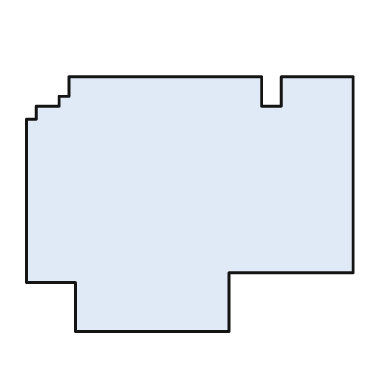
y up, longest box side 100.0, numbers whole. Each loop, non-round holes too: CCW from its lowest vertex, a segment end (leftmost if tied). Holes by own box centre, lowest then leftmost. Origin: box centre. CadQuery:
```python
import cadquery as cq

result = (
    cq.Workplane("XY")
    .moveTo(-35.0, -39.0)
    .lineTo(12.0, -39.0)
    .lineTo(12.0, -21.0)
    .lineTo(50.0, -21.0)
    .lineTo(50.0, 39.0)
    .lineTo(28.0, 39.0)
    .lineTo(28.0, 30.0)
    .lineTo(22.0, 30.0)
    .lineTo(22.0, 39.0)
    .lineTo(-37.0, 39.0)
    .lineTo(-37.0, 33.0)
    .lineTo(-40.0, 33.0)
    .lineTo(-40.0, 30.0)
    .lineTo(-47.0, 30.0)
    .lineTo(-47.0, 26.0)
    .lineTo(-50.0, 26.0)
    .lineTo(-50.0, -24.0)
    .lineTo(-35.0, -24.0)
    .close()
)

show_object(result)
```